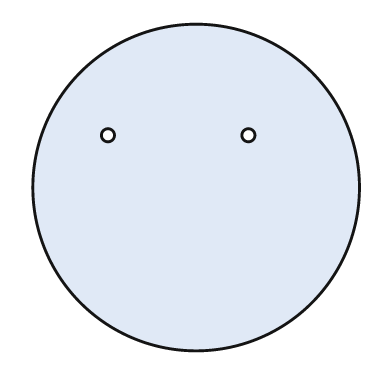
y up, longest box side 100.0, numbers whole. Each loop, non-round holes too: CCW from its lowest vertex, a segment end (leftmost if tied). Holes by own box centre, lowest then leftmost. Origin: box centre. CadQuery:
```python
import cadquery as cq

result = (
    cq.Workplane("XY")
    .moveTo(0.0, 0.0)
    .circle(50.0)
    .moveTo(-27.0, 16.0)
    .circle(2.0)
    .moveTo(16.0, 16.0)
    .circle(2.0)
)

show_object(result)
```